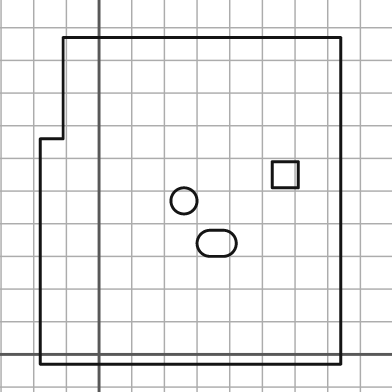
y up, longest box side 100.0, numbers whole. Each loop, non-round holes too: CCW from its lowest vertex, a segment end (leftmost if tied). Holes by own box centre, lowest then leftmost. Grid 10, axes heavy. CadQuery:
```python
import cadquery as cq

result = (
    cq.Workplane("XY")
    .moveTo(-18.0, -3.0)
    .lineTo(74.0, -3.0)
    .lineTo(74.0, 97.0)
    .lineTo(-11.0, 97.0)
    .lineTo(-11.0, 66.0)
    .lineTo(-18.0, 66.0)
    .close()
    .moveTo(34.0, 30.0)
    .lineTo(38.0, 30.0)
    .threePointArc((42.0, 34.0), (38.0, 38.0))
    .lineTo(34.0, 38.0)
    .threePointArc((30.0, 34.0), (34.0, 30.0))
    .close()
    .moveTo(26.0, 47.0)
    .circle(4.0)
    .moveTo(53.0, 51.0)
    .lineTo(61.0, 51.0)
    .lineTo(61.0, 59.0)
    .lineTo(53.0, 59.0)
    .close()
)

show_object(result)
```